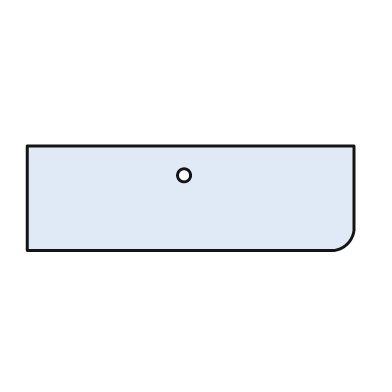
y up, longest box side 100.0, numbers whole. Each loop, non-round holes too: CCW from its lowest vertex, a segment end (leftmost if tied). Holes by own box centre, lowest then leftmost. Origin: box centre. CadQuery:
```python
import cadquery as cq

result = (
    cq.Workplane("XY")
    .moveTo(-50.0, -16.0)
    .lineTo(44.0, -16.0)
    .threePointArc((48.0, -14.0), (50.0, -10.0))
    .lineTo(50.0, 16.0)
    .lineTo(-50.0, 16.0)
    .close()
    .moveTo(-2.0, 7.0)
    .circle(2.0)
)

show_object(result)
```